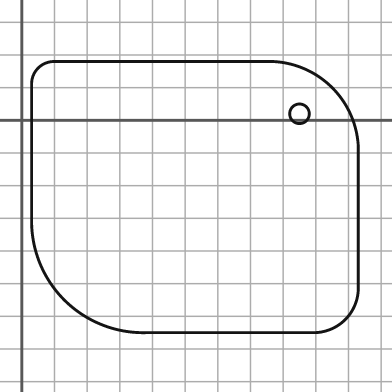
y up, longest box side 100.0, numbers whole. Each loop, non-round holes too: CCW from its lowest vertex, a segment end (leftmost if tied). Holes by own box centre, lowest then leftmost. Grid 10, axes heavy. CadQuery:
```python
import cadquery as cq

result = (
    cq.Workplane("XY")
    .moveTo(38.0, -65.0)
    .lineTo(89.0, -65.0)
    .threePointArc((99.0, -61.0), (103.0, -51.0))
    .lineTo(103.0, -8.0)
    .threePointArc((95.0, 10.0), (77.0, 18.0))
    .lineTo(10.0, 18.0)
    .threePointArc((5.0, 16.0), (3.0, 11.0))
    .lineTo(3.0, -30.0)
    .threePointArc((13.0, -55.0), (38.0, -65.0))
    .close()
    .moveTo(85.0, 2.0)
    .circle(3.0)
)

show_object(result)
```